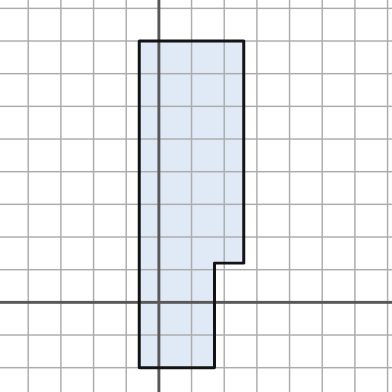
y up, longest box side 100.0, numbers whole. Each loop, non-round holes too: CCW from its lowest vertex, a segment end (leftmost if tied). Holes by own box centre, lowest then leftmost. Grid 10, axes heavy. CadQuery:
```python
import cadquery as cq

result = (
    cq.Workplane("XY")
    .moveTo(-6.0, -20.0)
    .lineTo(17.0, -20.0)
    .lineTo(17.0, 12.0)
    .lineTo(26.0, 12.0)
    .lineTo(26.0, 80.0)
    .lineTo(-6.0, 80.0)
    .close()
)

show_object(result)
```